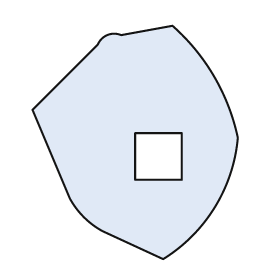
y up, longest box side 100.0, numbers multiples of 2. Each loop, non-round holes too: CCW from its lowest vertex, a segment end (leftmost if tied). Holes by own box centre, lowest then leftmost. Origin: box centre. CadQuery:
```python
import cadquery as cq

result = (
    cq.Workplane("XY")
    .moveTo(12.0, -50.0)
    .threePointArc((34.0, -28.0), (44.0, 2.0))
    .threePointArc((34.0, 28.0), (16.0, 50.0))
    .lineTo(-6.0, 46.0)
    .threePointArc((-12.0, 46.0), (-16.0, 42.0))
    .lineTo(-44.0, 14.0)
    .lineTo(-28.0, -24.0)
    .threePointArc((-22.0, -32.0), (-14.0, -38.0))
    .close()
    .moveTo(0.0, -16.0)
    .lineTo(20.0, -16.0)
    .lineTo(20.0, 4.0)
    .lineTo(0.0, 4.0)
    .close()
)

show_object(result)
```